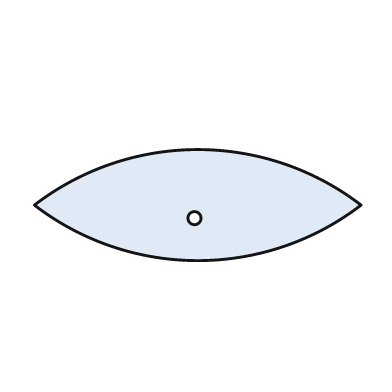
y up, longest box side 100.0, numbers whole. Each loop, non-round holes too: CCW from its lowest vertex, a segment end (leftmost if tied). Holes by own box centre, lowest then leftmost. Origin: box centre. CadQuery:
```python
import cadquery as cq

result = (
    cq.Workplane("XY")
    .moveTo(-50.0, 0.0)
    .threePointArc((0.0, -17.0), (50.0, 0.0))
    .threePointArc((0.0, 17.0), (-50.0, 0.0))
    .close()
    .moveTo(-1.0, -4.0)
    .circle(2.0)
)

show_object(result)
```